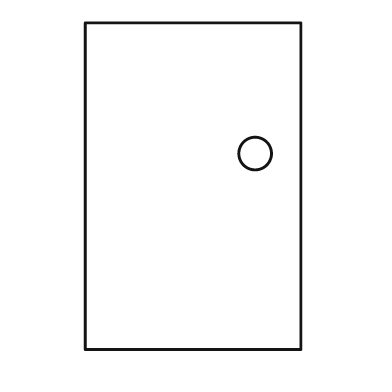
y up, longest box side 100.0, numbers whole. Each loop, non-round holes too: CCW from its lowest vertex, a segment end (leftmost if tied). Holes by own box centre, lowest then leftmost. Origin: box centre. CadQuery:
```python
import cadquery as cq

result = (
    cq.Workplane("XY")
    .moveTo(-33.0, -50.0)
    .lineTo(33.0, -50.0)
    .lineTo(33.0, 50.0)
    .lineTo(-33.0, 50.0)
    .close()
    .moveTo(19.0, 10.0)
    .circle(5.0)
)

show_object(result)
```